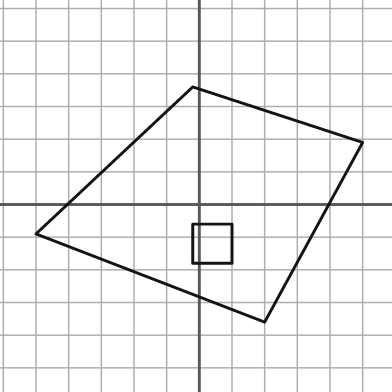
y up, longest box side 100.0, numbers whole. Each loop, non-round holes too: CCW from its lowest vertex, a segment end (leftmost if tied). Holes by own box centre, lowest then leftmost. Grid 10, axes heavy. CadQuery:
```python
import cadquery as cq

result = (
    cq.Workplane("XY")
    .moveTo(20.0, -36.0)
    .lineTo(50.0, 19.0)
    .lineTo(-2.0, 36.0)
    .lineTo(-50.0, -9.0)
    .close()
    .moveTo(-2.0, -18.0)
    .lineTo(10.0, -18.0)
    .lineTo(10.0, -6.0)
    .lineTo(-2.0, -6.0)
    .close()
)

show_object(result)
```